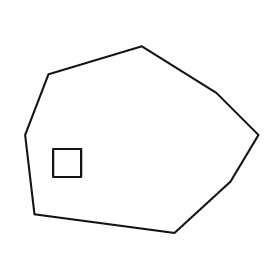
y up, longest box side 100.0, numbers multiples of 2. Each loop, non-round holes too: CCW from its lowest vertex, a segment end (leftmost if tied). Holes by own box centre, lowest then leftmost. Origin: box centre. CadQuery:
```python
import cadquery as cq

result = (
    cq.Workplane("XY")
    .moveTo(14.0, -40.0)
    .lineTo(38.0, -18.0)
    .lineTo(50.0, 2.0)
    .lineTo(32.0, 20.0)
    .lineTo(0.0, 40.0)
    .lineTo(-40.0, 28.0)
    .lineTo(-50.0, 2.0)
    .lineTo(-46.0, -32.0)
    .close()
    .moveTo(-38.0, -16.0)
    .lineTo(-26.0, -16.0)
    .lineTo(-26.0, -4.0)
    .lineTo(-38.0, -4.0)
    .close()
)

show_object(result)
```